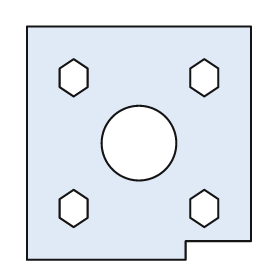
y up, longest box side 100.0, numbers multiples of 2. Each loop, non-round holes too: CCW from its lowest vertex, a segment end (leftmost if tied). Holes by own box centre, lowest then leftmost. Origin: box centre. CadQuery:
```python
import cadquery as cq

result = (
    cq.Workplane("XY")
    .moveTo(-48.0, -50.0)
    .lineTo(20.0, -50.0)
    .lineTo(20.0, -42.0)
    .lineTo(48.0, -42.0)
    .lineTo(48.0, 50.0)
    .lineTo(-48.0, 50.0)
    .close()
    .moveTo(-28.0, -36.0)
    .lineTo(-22.0, -32.0)
    .lineTo(-22.0, -24.0)
    .lineTo(-28.0, -20.0)
    .lineTo(-34.0, -24.0)
    .lineTo(-34.0, -32.0)
    .close()
    .moveTo(28.0, -36.0)
    .lineTo(34.0, -32.0)
    .lineTo(34.0, -24.0)
    .lineTo(28.0, -20.0)
    .lineTo(22.0, -24.0)
    .lineTo(22.0, -32.0)
    .close()
    .moveTo(0.0, 0.0)
    .circle(16.0)
    .moveTo(-28.0, 20.0)
    .lineTo(-22.0, 24.0)
    .lineTo(-22.0, 32.0)
    .lineTo(-28.0, 36.0)
    .lineTo(-34.0, 32.0)
    .lineTo(-34.0, 24.0)
    .close()
    .moveTo(28.0, 20.0)
    .lineTo(34.0, 24.0)
    .lineTo(34.0, 32.0)
    .lineTo(28.0, 36.0)
    .lineTo(22.0, 32.0)
    .lineTo(22.0, 24.0)
    .close()
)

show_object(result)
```